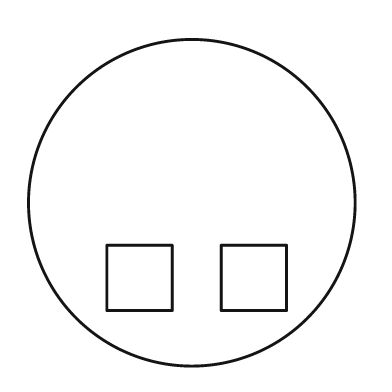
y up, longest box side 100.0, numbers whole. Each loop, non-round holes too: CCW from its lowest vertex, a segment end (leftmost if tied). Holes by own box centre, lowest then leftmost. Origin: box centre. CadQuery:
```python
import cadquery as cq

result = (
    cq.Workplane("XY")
    .moveTo(0.0, 0.0)
    .circle(50.0)
    .moveTo(-26.0, -33.0)
    .lineTo(-6.0, -33.0)
    .lineTo(-6.0, -13.0)
    .lineTo(-26.0, -13.0)
    .close()
    .moveTo(9.0, -33.0)
    .lineTo(29.0, -33.0)
    .lineTo(29.0, -13.0)
    .lineTo(9.0, -13.0)
    .close()
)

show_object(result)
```